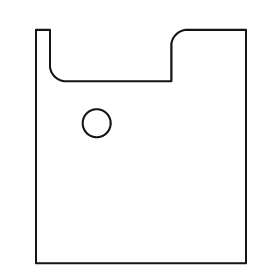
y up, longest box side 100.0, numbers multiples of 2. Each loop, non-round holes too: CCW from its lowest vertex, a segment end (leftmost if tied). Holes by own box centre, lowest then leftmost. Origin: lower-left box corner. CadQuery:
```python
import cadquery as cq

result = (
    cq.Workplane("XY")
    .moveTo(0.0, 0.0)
    .lineTo(90.0, 0.0)
    .lineTo(90.0, 100.0)
    .lineTo(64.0, 100.0)
    .threePointArc((60.0, 98.0), (58.0, 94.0))
    .lineTo(58.0, 78.0)
    .lineTo(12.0, 78.0)
    .threePointArc((8.0, 80.0), (6.0, 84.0))
    .lineTo(6.0, 100.0)
    .lineTo(0.0, 100.0)
    .close()
    .moveTo(26.0, 60.0)
    .circle(6.0)
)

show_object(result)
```